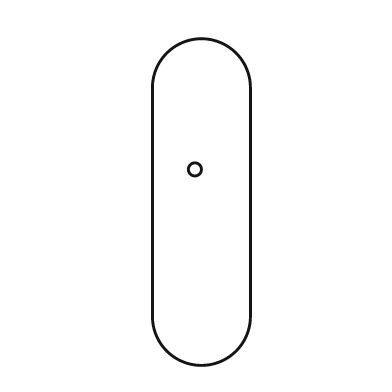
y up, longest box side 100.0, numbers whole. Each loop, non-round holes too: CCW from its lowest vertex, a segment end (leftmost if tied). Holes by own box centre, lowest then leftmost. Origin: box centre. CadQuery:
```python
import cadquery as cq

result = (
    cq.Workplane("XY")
    .moveTo(-15.0, -35.0)
    .threePointArc((0.0, -50.0), (15.0, -35.0))
    .lineTo(15.0, 35.0)
    .threePointArc((0.0, 50.0), (-15.0, 35.0))
    .close()
    .moveTo(-2.0, 10.0)
    .circle(2.0)
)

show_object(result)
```